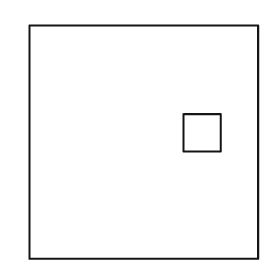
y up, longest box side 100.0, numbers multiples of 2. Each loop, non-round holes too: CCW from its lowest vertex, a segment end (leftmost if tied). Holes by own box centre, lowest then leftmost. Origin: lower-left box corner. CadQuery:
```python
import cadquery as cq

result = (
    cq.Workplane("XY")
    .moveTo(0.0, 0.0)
    .lineTo(98.0, 0.0)
    .lineTo(98.0, 100.0)
    .lineTo(0.0, 100.0)
    .close()
    .moveTo(66.0, 46.0)
    .lineTo(82.0, 46.0)
    .lineTo(82.0, 62.0)
    .lineTo(66.0, 62.0)
    .close()
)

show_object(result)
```